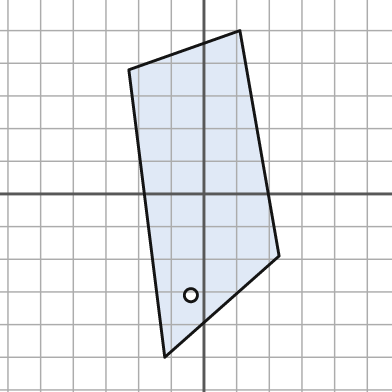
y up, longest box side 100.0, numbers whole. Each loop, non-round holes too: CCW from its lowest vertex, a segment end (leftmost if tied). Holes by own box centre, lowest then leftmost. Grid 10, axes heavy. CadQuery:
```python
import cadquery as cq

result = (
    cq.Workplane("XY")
    .moveTo(-12.0, -50.0)
    .lineTo(23.0, -19.0)
    .lineTo(11.0, 50.0)
    .lineTo(-23.0, 38.0)
    .close()
    .moveTo(-4.0, -31.0)
    .circle(2.0)
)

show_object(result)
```